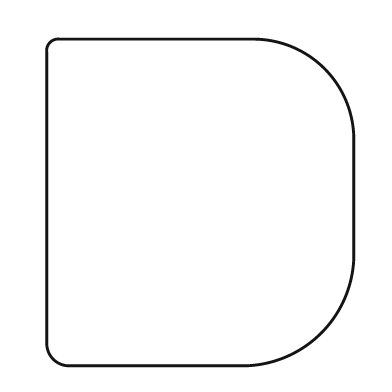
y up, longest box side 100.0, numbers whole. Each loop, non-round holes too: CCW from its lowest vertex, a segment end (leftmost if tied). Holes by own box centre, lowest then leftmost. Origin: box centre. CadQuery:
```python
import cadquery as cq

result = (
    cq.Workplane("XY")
    .moveTo(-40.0, -50.0)
    .lineTo(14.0, -50.0)
    .threePointArc((37.0, -40.0), (47.0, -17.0))
    .lineTo(47.0, 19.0)
    .threePointArc((38.0, 41.0), (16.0, 50.0))
    .lineTo(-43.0, 50.0)
    .threePointArc((-46.0, 49.0), (-47.0, 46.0))
    .lineTo(-47.0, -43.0)
    .threePointArc((-45.0, -48.0), (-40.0, -50.0))
    .close()
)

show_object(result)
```